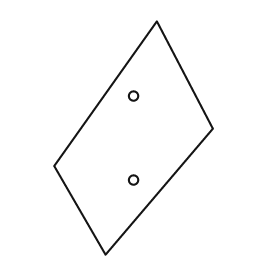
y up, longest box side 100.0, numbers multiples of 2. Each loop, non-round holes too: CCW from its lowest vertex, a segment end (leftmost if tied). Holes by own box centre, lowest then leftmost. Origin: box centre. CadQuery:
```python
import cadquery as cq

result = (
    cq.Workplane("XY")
    .moveTo(-12.0, -50.0)
    .lineTo(34.0, 4.0)
    .lineTo(10.0, 50.0)
    .lineTo(-34.0, -12.0)
    .close()
    .moveTo(0.0, -18.0)
    .circle(2.0)
    .moveTo(0.0, 18.0)
    .circle(2.0)
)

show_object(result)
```